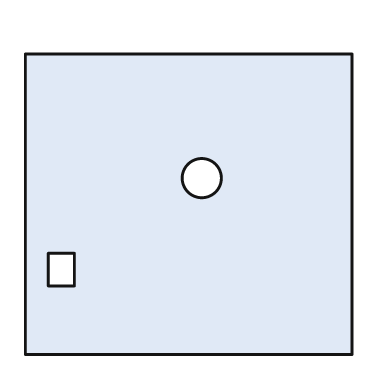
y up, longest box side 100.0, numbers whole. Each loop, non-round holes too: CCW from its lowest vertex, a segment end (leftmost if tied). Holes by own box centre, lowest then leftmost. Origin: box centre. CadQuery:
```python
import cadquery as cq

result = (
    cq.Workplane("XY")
    .moveTo(-50.0, -46.0)
    .lineTo(50.0, -46.0)
    .lineTo(50.0, 46.0)
    .lineTo(-50.0, 46.0)
    .close()
    .moveTo(-43.0, -25.0)
    .lineTo(-35.0, -25.0)
    .lineTo(-35.0, -15.0)
    .lineTo(-43.0, -15.0)
    .close()
    .moveTo(4.0, 8.0)
    .circle(6.0)
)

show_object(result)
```